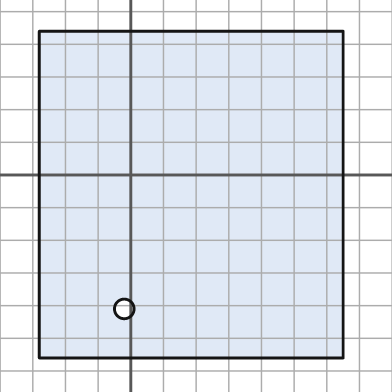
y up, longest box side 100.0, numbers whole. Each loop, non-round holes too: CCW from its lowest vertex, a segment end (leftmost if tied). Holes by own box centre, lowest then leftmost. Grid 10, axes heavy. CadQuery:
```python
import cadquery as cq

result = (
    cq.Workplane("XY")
    .moveTo(-28.0, -56.0)
    .lineTo(65.0, -56.0)
    .lineTo(65.0, 44.0)
    .lineTo(-28.0, 44.0)
    .close()
    .moveTo(-2.0, -41.0)
    .circle(3.0)
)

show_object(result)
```